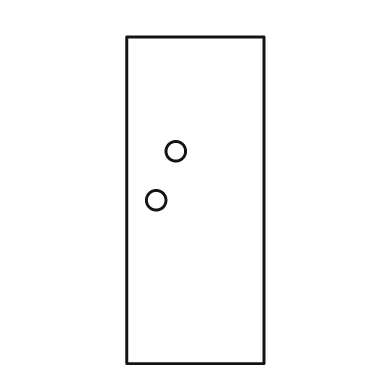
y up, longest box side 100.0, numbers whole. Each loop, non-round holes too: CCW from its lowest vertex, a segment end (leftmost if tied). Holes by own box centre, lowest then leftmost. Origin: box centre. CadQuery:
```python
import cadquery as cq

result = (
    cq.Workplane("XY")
    .moveTo(-21.0, -50.0)
    .lineTo(21.0, -50.0)
    .lineTo(21.0, 50.0)
    .lineTo(-21.0, 50.0)
    .close()
    .moveTo(-12.0, 0.0)
    .circle(3.0)
    .moveTo(-6.0, 15.0)
    .circle(3.0)
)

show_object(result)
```